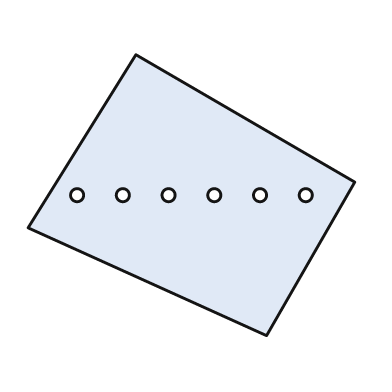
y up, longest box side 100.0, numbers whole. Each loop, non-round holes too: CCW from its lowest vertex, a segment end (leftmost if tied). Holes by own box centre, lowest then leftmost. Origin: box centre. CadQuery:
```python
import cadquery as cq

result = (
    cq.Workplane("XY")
    .moveTo(23.0, -43.0)
    .lineTo(50.0, 4.0)
    .lineTo(-17.0, 43.0)
    .lineTo(-50.0, -10.0)
    .close()
    .moveTo(-35.0, 0.0)
    .circle(2.0)
    .moveTo(-21.0, 0.0)
    .circle(2.0)
    .moveTo(-7.0, 0.0)
    .circle(2.0)
    .moveTo(7.0, 0.0)
    .circle(2.0)
    .moveTo(21.0, 0.0)
    .circle(2.0)
    .moveTo(35.0, 0.0)
    .circle(2.0)
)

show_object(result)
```